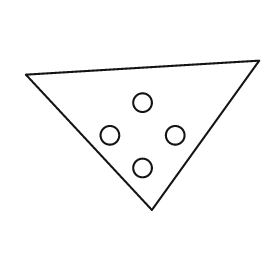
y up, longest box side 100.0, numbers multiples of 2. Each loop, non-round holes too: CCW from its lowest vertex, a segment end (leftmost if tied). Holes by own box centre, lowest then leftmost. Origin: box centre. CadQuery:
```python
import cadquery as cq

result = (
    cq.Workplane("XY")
    .moveTo(4.0, -32.0)
    .lineTo(50.0, 32.0)
    .lineTo(-50.0, 26.0)
    .close()
    .moveTo(0.0, -14.0)
    .circle(4.0)
    .moveTo(-14.0, 0.0)
    .circle(4.0)
    .moveTo(14.0, 0.0)
    .circle(4.0)
    .moveTo(0.0, 14.0)
    .circle(4.0)
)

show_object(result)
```